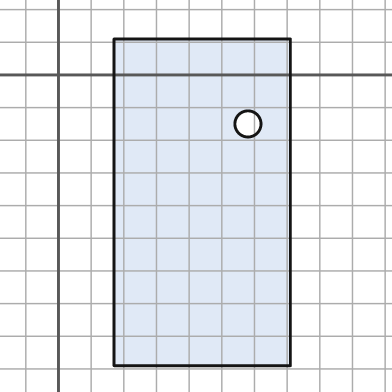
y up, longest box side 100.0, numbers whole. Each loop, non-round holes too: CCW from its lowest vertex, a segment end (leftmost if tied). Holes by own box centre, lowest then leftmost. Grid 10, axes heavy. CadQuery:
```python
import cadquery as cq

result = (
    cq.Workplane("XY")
    .moveTo(17.0, -89.0)
    .lineTo(71.0, -89.0)
    .lineTo(71.0, 11.0)
    .lineTo(17.0, 11.0)
    .close()
    .moveTo(58.0, -15.0)
    .circle(4.0)
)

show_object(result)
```